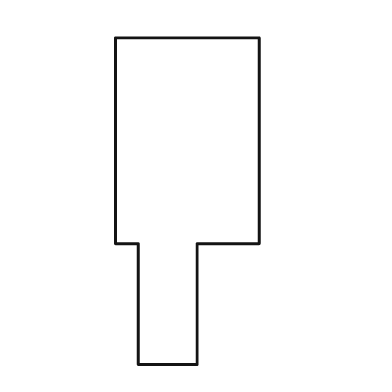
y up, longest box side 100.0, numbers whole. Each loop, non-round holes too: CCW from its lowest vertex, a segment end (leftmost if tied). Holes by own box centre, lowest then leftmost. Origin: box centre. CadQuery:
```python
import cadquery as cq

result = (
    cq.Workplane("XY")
    .moveTo(-15.0, -50.0)
    .lineTo(3.0, -50.0)
    .lineTo(3.0, -13.0)
    .lineTo(22.0, -13.0)
    .lineTo(22.0, 50.0)
    .lineTo(-22.0, 50.0)
    .lineTo(-22.0, -13.0)
    .lineTo(-15.0, -13.0)
    .close()
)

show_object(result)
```